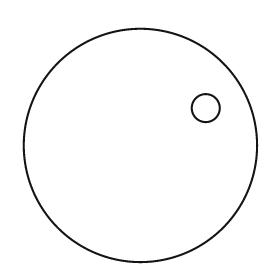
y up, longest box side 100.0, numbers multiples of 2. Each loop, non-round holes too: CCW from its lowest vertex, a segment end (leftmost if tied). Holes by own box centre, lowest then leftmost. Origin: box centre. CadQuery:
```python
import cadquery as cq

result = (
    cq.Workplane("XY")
    .moveTo(0.0, 0.0)
    .circle(50.0)
    .moveTo(28.0, 16.0)
    .circle(6.0)
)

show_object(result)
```